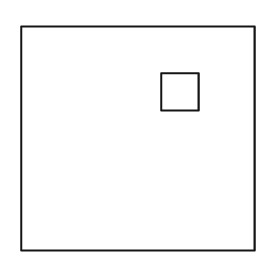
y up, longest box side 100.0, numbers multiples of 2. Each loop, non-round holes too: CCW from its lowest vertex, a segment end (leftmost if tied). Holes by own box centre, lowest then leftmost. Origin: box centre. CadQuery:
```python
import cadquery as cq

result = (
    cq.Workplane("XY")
    .moveTo(-50.0, -48.0)
    .lineTo(50.0, -48.0)
    .lineTo(50.0, 48.0)
    .lineTo(-50.0, 48.0)
    .close()
    .moveTo(10.0, 12.0)
    .lineTo(26.0, 12.0)
    .lineTo(26.0, 28.0)
    .lineTo(10.0, 28.0)
    .close()
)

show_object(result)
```